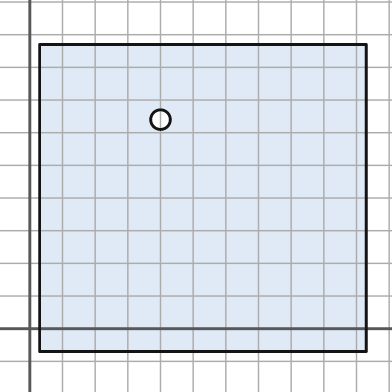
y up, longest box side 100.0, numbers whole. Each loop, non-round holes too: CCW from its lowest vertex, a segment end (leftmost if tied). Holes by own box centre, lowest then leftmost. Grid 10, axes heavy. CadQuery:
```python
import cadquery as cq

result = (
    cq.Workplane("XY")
    .moveTo(3.0, -7.0)
    .lineTo(103.0, -7.0)
    .lineTo(103.0, 87.0)
    .lineTo(3.0, 87.0)
    .close()
    .moveTo(40.0, 64.0)
    .circle(3.0)
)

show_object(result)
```